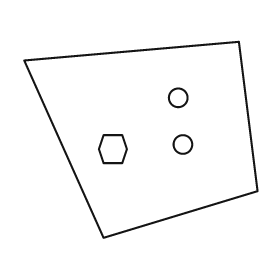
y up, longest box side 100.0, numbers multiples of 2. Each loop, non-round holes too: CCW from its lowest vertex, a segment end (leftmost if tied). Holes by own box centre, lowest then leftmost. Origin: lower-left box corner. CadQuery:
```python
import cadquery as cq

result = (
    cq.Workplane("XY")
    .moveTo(34.0, 0.0)
    .lineTo(100.0, 20.0)
    .lineTo(92.0, 84.0)
    .lineTo(0.0, 76.0)
    .close()
    .moveTo(34.0, 32.0)
    .lineTo(42.0, 32.0)
    .lineTo(44.0, 38.0)
    .lineTo(42.0, 44.0)
    .lineTo(34.0, 44.0)
    .lineTo(32.0, 38.0)
    .close()
    .moveTo(68.0, 40.0)
    .circle(4.0)
    .moveTo(66.0, 60.0)
    .circle(4.0)
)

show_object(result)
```